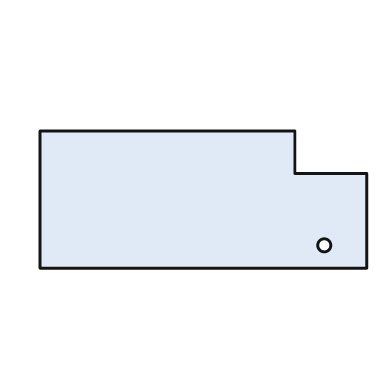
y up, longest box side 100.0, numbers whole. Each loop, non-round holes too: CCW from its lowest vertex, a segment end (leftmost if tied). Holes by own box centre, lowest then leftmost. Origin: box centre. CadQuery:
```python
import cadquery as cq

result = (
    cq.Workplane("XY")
    .moveTo(-50.0, -21.0)
    .lineTo(50.0, -21.0)
    .lineTo(50.0, 8.0)
    .lineTo(28.0, 8.0)
    .lineTo(28.0, 21.0)
    .lineTo(-50.0, 21.0)
    .close()
    .moveTo(37.0, -14.0)
    .circle(2.0)
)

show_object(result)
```